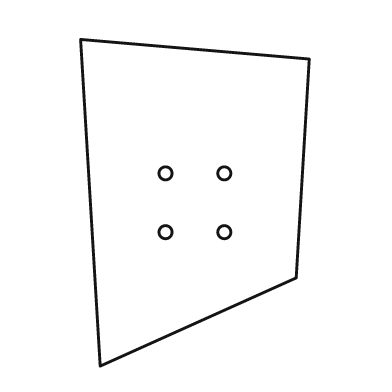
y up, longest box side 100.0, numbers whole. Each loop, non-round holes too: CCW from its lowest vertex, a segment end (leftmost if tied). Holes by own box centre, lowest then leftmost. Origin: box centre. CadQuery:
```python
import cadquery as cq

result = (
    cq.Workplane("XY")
    .moveTo(-29.0, -50.0)
    .lineTo(31.0, -23.0)
    .lineTo(35.0, 44.0)
    .lineTo(-35.0, 50.0)
    .close()
    .moveTo(-9.0, -9.0)
    .circle(2.0)
    .moveTo(9.0, -9.0)
    .circle(2.0)
    .moveTo(-9.0, 9.0)
    .circle(2.0)
    .moveTo(9.0, 9.0)
    .circle(2.0)
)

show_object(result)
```